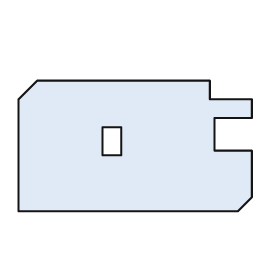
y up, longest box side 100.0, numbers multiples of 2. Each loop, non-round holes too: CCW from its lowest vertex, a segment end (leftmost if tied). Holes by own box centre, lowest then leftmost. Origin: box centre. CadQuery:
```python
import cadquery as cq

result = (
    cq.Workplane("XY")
    .moveTo(-50.0, -28.0)
    .lineTo(44.0, -28.0)
    .lineTo(50.0, -22.0)
    .lineTo(50.0, -2.0)
    .lineTo(34.0, -2.0)
    .lineTo(34.0, 12.0)
    .lineTo(50.0, 12.0)
    .lineTo(50.0, 20.0)
    .lineTo(32.0, 20.0)
    .lineTo(32.0, 28.0)
    .lineTo(-42.0, 28.0)
    .lineTo(-50.0, 20.0)
    .close()
    .moveTo(-14.0, -4.0)
    .lineTo(-6.0, -4.0)
    .lineTo(-6.0, 8.0)
    .lineTo(-14.0, 8.0)
    .close()
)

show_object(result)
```